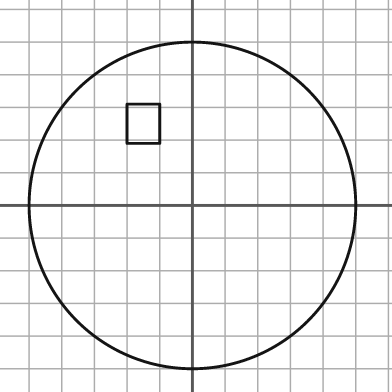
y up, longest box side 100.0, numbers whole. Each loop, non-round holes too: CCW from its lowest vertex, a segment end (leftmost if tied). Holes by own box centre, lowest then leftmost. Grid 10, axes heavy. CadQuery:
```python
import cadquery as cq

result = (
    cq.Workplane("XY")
    .moveTo(0.0, 0.0)
    .circle(50.0)
    .moveTo(-20.0, 19.0)
    .lineTo(-10.0, 19.0)
    .lineTo(-10.0, 31.0)
    .lineTo(-20.0, 31.0)
    .close()
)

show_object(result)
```